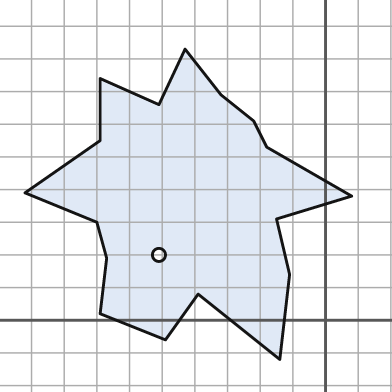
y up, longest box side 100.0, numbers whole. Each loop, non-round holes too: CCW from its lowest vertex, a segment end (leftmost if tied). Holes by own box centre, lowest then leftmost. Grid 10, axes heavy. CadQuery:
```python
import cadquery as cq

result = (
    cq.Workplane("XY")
    .moveTo(-14.0, -12.0)
    .lineTo(-11.0, 14.0)
    .lineTo(-15.0, 31.0)
    .lineTo(8.0, 38.0)
    .lineTo(-18.0, 53.0)
    .lineTo(-22.0, 61.0)
    .lineTo(-32.0, 69.0)
    .lineTo(-43.0, 83.0)
    .lineTo(-51.0, 66.0)
    .lineTo(-69.0, 74.0)
    .lineTo(-69.0, 55.0)
    .lineTo(-92.0, 39.0)
    .lineTo(-70.0, 30.0)
    .lineTo(-67.0, 19.0)
    .lineTo(-69.0, 2.0)
    .lineTo(-49.0, -6.0)
    .lineTo(-39.0, 8.0)
    .close()
    .moveTo(-51.0, 20.0)
    .circle(2.0)
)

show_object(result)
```